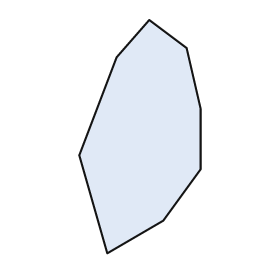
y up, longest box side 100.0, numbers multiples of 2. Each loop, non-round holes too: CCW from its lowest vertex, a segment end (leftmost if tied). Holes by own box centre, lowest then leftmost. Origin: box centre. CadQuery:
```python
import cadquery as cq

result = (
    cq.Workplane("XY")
    .moveTo(-14.0, -50.0)
    .lineTo(10.0, -36.0)
    .lineTo(26.0, -14.0)
    .lineTo(26.0, 12.0)
    .lineTo(20.0, 38.0)
    .lineTo(4.0, 50.0)
    .lineTo(-10.0, 34.0)
    .lineTo(-26.0, -8.0)
    .close()
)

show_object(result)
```